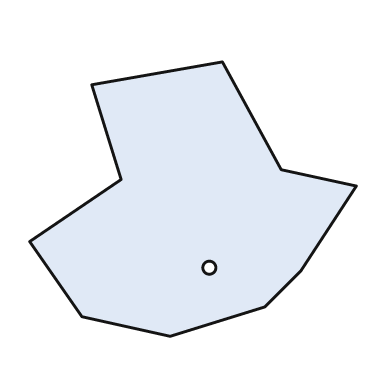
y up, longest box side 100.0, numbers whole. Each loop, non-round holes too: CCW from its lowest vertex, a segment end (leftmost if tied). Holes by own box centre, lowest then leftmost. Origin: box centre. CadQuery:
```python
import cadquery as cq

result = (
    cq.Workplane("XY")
    .moveTo(-7.0, -42.0)
    .lineTo(22.0, -33.0)
    .lineTo(33.0, -22.0)
    .lineTo(50.0, 4.0)
    .lineTo(27.0, 9.0)
    .lineTo(9.0, 42.0)
    .lineTo(-31.0, 35.0)
    .lineTo(-22.0, 6.0)
    .lineTo(-50.0, -13.0)
    .lineTo(-34.0, -36.0)
    .close()
    .moveTo(5.0, -21.0)
    .circle(2.0)
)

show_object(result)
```